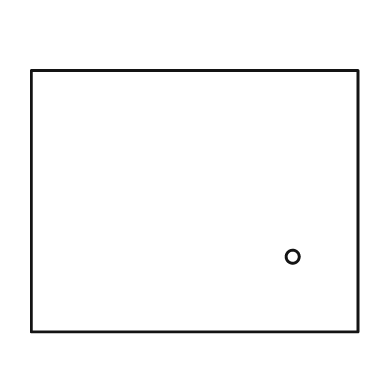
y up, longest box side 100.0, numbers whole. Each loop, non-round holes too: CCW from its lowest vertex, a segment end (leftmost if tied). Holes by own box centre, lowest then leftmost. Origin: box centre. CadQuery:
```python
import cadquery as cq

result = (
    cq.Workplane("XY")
    .moveTo(-50.0, -40.0)
    .lineTo(50.0, -40.0)
    .lineTo(50.0, 40.0)
    .lineTo(-50.0, 40.0)
    .close()
    .moveTo(30.0, -17.0)
    .circle(2.0)
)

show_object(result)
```